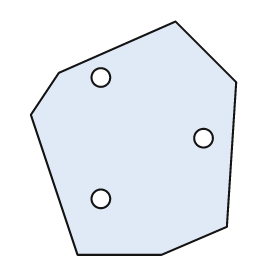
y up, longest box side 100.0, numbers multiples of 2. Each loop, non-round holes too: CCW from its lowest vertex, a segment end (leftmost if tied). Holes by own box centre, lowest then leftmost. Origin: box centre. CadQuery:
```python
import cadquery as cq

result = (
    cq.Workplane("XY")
    .moveTo(-24.0, -50.0)
    .lineTo(12.0, -50.0)
    .lineTo(40.0, -38.0)
    .lineTo(44.0, 24.0)
    .lineTo(18.0, 50.0)
    .lineTo(-32.0, 28.0)
    .lineTo(-44.0, 10.0)
    .close()
    .moveTo(-14.0, -26.0)
    .circle(4.0)
    .moveTo(30.0, 0.0)
    .circle(4.0)
    .moveTo(-14.0, 26.0)
    .circle(4.0)
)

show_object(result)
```